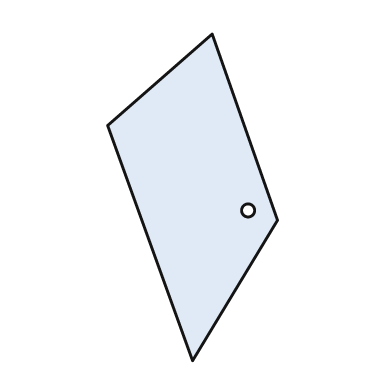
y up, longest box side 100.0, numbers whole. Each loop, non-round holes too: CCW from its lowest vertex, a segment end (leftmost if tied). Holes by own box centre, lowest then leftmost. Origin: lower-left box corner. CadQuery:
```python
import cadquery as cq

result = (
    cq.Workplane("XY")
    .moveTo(26.0, 0.0)
    .lineTo(52.0, 43.0)
    .lineTo(32.0, 100.0)
    .lineTo(0.0, 72.0)
    .close()
    .moveTo(43.0, 46.0)
    .circle(2.0)
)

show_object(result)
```